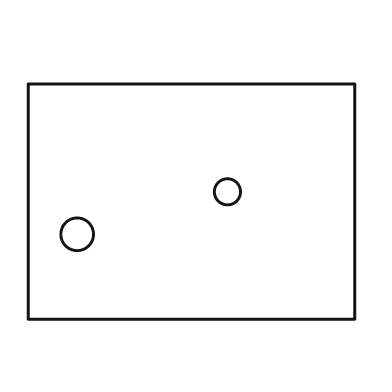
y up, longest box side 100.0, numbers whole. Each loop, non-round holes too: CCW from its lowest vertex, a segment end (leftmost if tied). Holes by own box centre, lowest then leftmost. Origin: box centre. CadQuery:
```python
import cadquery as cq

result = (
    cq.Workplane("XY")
    .moveTo(-50.0, -36.0)
    .lineTo(50.0, -36.0)
    .lineTo(50.0, 36.0)
    .lineTo(-50.0, 36.0)
    .close()
    .moveTo(-35.0, -10.0)
    .circle(5.0)
    .moveTo(11.0, 3.0)
    .circle(4.0)
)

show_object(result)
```